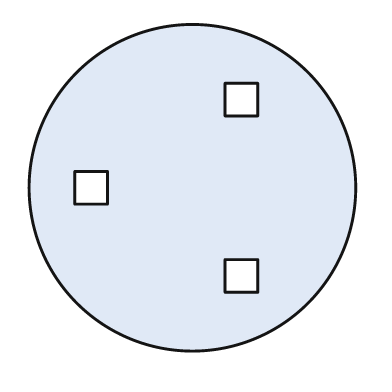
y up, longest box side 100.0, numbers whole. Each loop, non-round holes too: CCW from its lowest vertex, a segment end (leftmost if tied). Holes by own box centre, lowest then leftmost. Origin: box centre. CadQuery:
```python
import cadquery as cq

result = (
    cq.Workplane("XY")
    .moveTo(0.0, 0.0)
    .circle(50.0)
    .moveTo(10.0, -32.0)
    .lineTo(20.0, -32.0)
    .lineTo(20.0, -22.0)
    .lineTo(10.0, -22.0)
    .close()
    .moveTo(-36.0, -5.0)
    .lineTo(-26.0, -5.0)
    .lineTo(-26.0, 5.0)
    .lineTo(-36.0, 5.0)
    .close()
    .moveTo(10.0, 22.0)
    .lineTo(20.0, 22.0)
    .lineTo(20.0, 32.0)
    .lineTo(10.0, 32.0)
    .close()
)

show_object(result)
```